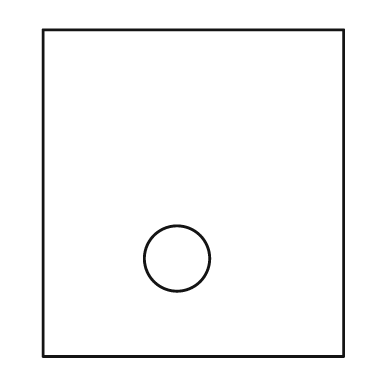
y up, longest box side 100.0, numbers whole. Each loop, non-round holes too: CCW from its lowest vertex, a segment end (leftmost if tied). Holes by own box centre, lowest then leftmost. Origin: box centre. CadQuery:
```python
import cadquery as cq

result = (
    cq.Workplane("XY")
    .moveTo(-46.0, -50.0)
    .lineTo(46.0, -50.0)
    .lineTo(46.0, 50.0)
    .lineTo(-46.0, 50.0)
    .close()
    .moveTo(-5.0, -20.0)
    .circle(10.0)
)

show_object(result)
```